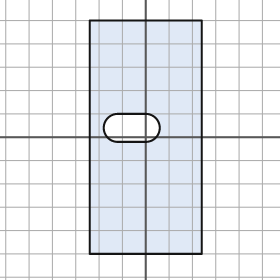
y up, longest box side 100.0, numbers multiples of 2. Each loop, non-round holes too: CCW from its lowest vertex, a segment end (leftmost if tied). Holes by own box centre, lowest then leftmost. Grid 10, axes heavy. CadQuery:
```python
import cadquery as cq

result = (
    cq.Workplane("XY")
    .moveTo(-24.0, -50.0)
    .lineTo(24.0, -50.0)
    .lineTo(24.0, 50.0)
    .lineTo(-24.0, 50.0)
    .close()
    .moveTo(-12.0, -2.0)
    .lineTo(0.0, -2.0)
    .threePointArc((6.0, 4.0), (0.0, 10.0))
    .lineTo(-12.0, 10.0)
    .threePointArc((-18.0, 4.0), (-12.0, -2.0))
    .close()
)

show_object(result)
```